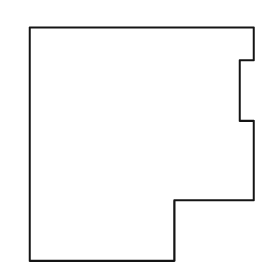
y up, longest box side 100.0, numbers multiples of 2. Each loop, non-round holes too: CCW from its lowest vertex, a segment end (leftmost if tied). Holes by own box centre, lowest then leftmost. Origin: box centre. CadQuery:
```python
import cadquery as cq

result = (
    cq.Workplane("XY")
    .moveTo(-48.0, -50.0)
    .lineTo(14.0, -50.0)
    .lineTo(14.0, -24.0)
    .lineTo(48.0, -24.0)
    .lineTo(48.0, 10.0)
    .lineTo(42.0, 10.0)
    .lineTo(42.0, 36.0)
    .lineTo(48.0, 36.0)
    .lineTo(48.0, 50.0)
    .lineTo(-48.0, 50.0)
    .close()
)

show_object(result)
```